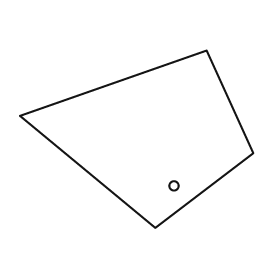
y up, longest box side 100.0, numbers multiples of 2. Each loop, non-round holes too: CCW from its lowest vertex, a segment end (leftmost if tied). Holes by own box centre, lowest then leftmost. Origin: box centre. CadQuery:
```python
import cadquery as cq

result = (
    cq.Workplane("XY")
    .moveTo(8.0, -38.0)
    .lineTo(50.0, -6.0)
    .lineTo(30.0, 38.0)
    .lineTo(-50.0, 10.0)
    .close()
    .moveTo(16.0, -20.0)
    .circle(2.0)
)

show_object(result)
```